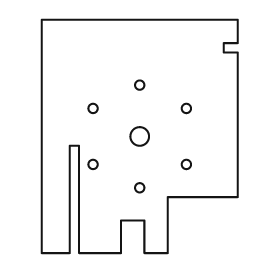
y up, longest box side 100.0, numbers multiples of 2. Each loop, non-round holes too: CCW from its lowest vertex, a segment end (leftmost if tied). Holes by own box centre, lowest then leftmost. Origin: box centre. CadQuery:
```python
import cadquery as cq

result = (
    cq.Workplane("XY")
    .moveTo(-42.0, -50.0)
    .lineTo(-30.0, -50.0)
    .lineTo(-30.0, -4.0)
    .lineTo(-26.0, -4.0)
    .lineTo(-26.0, -50.0)
    .lineTo(-8.0, -50.0)
    .lineTo(-8.0, -36.0)
    .lineTo(2.0, -36.0)
    .lineTo(2.0, -50.0)
    .lineTo(12.0, -50.0)
    .lineTo(12.0, -26.0)
    .lineTo(42.0, -26.0)
    .lineTo(42.0, 36.0)
    .lineTo(36.0, 36.0)
    .lineTo(36.0, 40.0)
    .lineTo(42.0, 40.0)
    .lineTo(42.0, 50.0)
    .lineTo(-42.0, 50.0)
    .close()
    .moveTo(0.0, -22.0)
    .circle(2.0)
    .moveTo(-20.0, -12.0)
    .circle(2.0)
    .moveTo(20.0, -12.0)
    .circle(2.0)
    .moveTo(0.0, 0.0)
    .circle(4.0)
    .moveTo(-20.0, 12.0)
    .circle(2.0)
    .moveTo(20.0, 12.0)
    .circle(2.0)
    .moveTo(0.0, 22.0)
    .circle(2.0)
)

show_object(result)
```